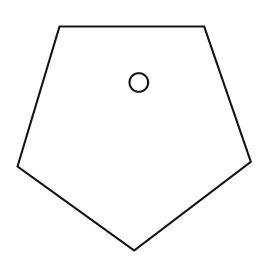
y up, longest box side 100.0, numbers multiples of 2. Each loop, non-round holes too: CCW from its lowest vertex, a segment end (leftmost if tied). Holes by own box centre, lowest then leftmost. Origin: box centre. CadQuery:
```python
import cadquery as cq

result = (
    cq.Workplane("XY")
    .moveTo(0.0, -48.0)
    .lineTo(50.0, -10.0)
    .lineTo(30.0, 48.0)
    .lineTo(-32.0, 48.0)
    .lineTo(-50.0, -12.0)
    .close()
    .moveTo(2.0, 24.0)
    .circle(4.0)
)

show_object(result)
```